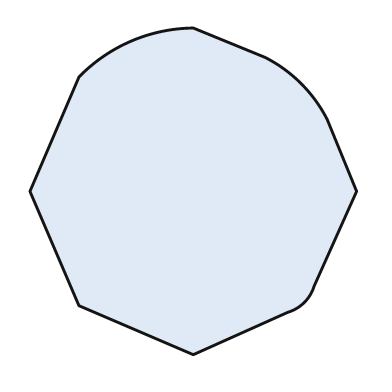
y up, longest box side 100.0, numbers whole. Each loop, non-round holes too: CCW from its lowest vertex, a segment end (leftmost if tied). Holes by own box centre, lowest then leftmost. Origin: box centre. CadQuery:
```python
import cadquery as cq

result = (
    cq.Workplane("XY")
    .moveTo(0.0, -50.0)
    .lineTo(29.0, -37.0)
    .threePointArc((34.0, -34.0), (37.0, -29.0))
    .lineTo(50.0, 0.0)
    .lineTo(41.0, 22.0)
    .threePointArc((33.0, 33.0), (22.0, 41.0))
    .lineTo(0.0, 50.0)
    .threePointArc((-19.0, 46.0), (-35.0, 35.0))
    .lineTo(-50.0, 0.0)
    .lineTo(-35.0, -35.0)
    .close()
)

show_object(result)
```